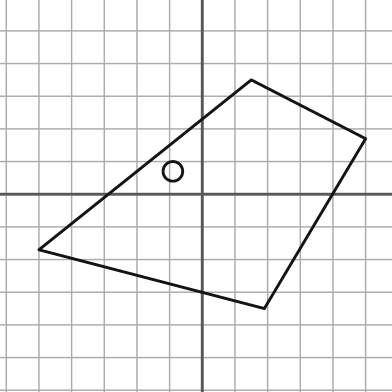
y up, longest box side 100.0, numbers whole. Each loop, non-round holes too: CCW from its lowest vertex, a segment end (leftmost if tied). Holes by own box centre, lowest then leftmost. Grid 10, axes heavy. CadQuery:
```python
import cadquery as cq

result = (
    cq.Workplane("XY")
    .moveTo(19.0, -35.0)
    .lineTo(50.0, 17.0)
    .lineTo(15.0, 35.0)
    .lineTo(-50.0, -17.0)
    .close()
    .moveTo(-9.0, 7.0)
    .circle(3.0)
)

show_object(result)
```